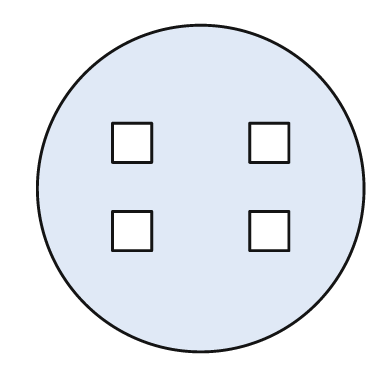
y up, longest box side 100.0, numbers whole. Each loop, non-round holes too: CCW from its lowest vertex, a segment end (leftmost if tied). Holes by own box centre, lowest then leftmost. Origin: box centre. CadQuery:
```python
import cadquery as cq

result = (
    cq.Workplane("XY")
    .moveTo(0.0, 0.0)
    .circle(50.0)
    .moveTo(-27.0, -19.0)
    .lineTo(-15.0, -19.0)
    .lineTo(-15.0, -7.0)
    .lineTo(-27.0, -7.0)
    .close()
    .moveTo(15.0, -19.0)
    .lineTo(27.0, -19.0)
    .lineTo(27.0, -7.0)
    .lineTo(15.0, -7.0)
    .close()
    .moveTo(-27.0, 8.0)
    .lineTo(-15.0, 8.0)
    .lineTo(-15.0, 20.0)
    .lineTo(-27.0, 20.0)
    .close()
    .moveTo(15.0, 8.0)
    .lineTo(27.0, 8.0)
    .lineTo(27.0, 20.0)
    .lineTo(15.0, 20.0)
    .close()
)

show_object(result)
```